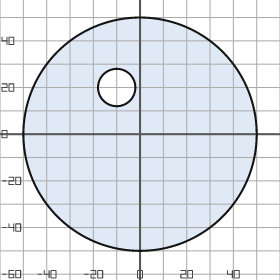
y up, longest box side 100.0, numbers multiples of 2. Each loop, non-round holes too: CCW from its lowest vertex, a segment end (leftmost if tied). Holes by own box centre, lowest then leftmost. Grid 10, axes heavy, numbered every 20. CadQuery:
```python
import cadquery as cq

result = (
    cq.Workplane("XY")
    .moveTo(0.0, 0.0)
    .circle(50.0)
    .moveTo(-10.0, 20.0)
    .circle(8.0)
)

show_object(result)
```